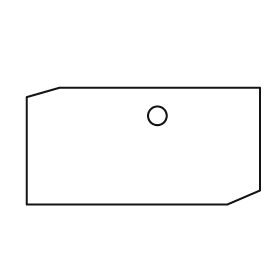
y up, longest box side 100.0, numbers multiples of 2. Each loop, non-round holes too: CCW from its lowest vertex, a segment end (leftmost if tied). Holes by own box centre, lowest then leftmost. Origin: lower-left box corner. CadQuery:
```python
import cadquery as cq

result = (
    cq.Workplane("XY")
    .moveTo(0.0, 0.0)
    .lineTo(86.0, 0.0)
    .lineTo(100.0, 6.0)
    .lineTo(100.0, 50.0)
    .lineTo(14.0, 50.0)
    .lineTo(0.0, 46.0)
    .close()
    .moveTo(56.0, 38.0)
    .circle(4.0)
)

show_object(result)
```